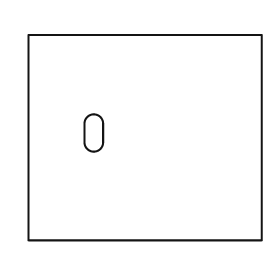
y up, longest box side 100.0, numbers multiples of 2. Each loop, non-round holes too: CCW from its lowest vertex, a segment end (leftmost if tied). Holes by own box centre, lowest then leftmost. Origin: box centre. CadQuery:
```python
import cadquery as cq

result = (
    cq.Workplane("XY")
    .moveTo(-50.0, -44.0)
    .lineTo(50.0, -44.0)
    .lineTo(50.0, 44.0)
    .lineTo(-50.0, 44.0)
    .close()
    .moveTo(-26.0, -2.0)
    .threePointArc((-22.0, -6.0), (-18.0, -2.0))
    .lineTo(-18.0, 6.0)
    .threePointArc((-22.0, 10.0), (-26.0, 6.0))
    .close()
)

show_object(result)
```